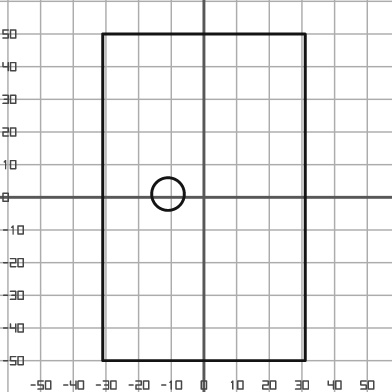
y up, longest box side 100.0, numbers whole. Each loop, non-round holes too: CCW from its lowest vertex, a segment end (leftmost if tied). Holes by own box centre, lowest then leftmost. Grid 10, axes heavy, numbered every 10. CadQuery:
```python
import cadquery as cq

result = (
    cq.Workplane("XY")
    .moveTo(-31.0, -50.0)
    .lineTo(31.0, -50.0)
    .lineTo(31.0, 50.0)
    .lineTo(-31.0, 50.0)
    .close()
    .moveTo(-11.0, 1.0)
    .circle(5.0)
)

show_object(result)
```